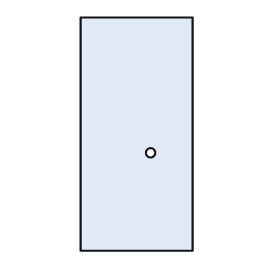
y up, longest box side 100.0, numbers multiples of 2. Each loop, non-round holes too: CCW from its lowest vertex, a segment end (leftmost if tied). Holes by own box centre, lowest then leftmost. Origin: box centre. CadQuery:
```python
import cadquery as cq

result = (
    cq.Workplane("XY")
    .moveTo(-24.0, -50.0)
    .lineTo(24.0, -50.0)
    .lineTo(24.0, 50.0)
    .lineTo(-24.0, 50.0)
    .close()
    .moveTo(6.0, -8.0)
    .circle(2.0)
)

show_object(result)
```